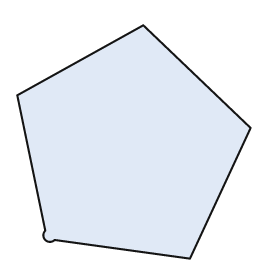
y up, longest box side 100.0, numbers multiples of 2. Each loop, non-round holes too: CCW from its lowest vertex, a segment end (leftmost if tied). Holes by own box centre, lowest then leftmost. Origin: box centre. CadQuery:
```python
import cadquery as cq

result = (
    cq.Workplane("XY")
    .moveTo(24.0, -50.0)
    .lineTo(50.0, 6.0)
    .lineTo(4.0, 50.0)
    .lineTo(-50.0, 20.0)
    .lineTo(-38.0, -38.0)
    .threePointArc((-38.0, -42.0), (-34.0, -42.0))
    .close()
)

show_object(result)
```